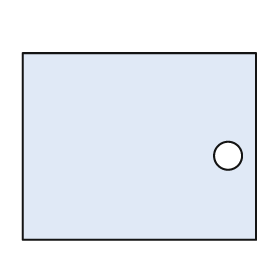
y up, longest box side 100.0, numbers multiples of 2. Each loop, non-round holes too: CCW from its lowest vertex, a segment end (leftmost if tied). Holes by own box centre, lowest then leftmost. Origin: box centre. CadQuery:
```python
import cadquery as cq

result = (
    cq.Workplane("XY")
    .moveTo(-50.0, -40.0)
    .lineTo(50.0, -40.0)
    .lineTo(50.0, 40.0)
    .lineTo(-50.0, 40.0)
    .close()
    .moveTo(38.0, -4.0)
    .circle(6.0)
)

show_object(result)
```